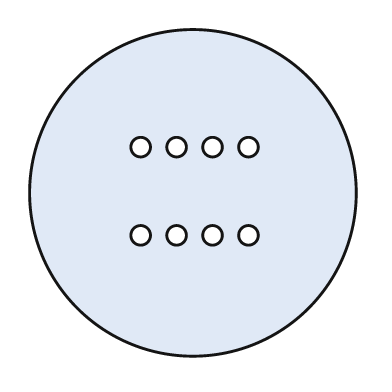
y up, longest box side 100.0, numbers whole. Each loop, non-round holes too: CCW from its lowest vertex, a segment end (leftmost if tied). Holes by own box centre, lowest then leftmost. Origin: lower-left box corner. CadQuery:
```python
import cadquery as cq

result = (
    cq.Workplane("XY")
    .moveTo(50.0, 50.0)
    .circle(50.0)
    .moveTo(34.0, 37.0)
    .circle(3.0)
    .moveTo(45.0, 37.0)
    .circle(3.0)
    .moveTo(56.0, 37.0)
    .circle(3.0)
    .moveTo(67.0, 37.0)
    .circle(3.0)
    .moveTo(34.0, 64.0)
    .circle(3.0)
    .moveTo(45.0, 64.0)
    .circle(3.0)
    .moveTo(56.0, 64.0)
    .circle(3.0)
    .moveTo(67.0, 64.0)
    .circle(3.0)
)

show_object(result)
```